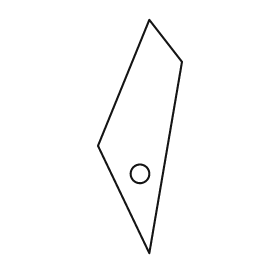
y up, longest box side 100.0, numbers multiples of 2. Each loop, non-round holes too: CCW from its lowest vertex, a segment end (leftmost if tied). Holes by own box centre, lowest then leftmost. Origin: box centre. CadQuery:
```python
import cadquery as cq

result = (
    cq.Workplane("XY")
    .moveTo(4.0, -50.0)
    .lineTo(18.0, 32.0)
    .lineTo(4.0, 50.0)
    .lineTo(-18.0, -4.0)
    .close()
    .moveTo(0.0, -16.0)
    .circle(4.0)
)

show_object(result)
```